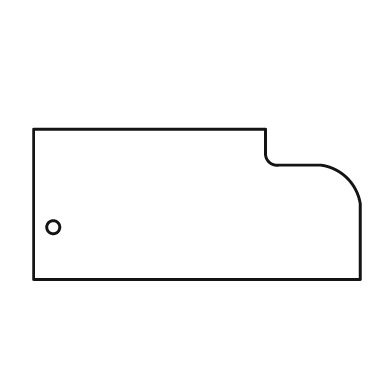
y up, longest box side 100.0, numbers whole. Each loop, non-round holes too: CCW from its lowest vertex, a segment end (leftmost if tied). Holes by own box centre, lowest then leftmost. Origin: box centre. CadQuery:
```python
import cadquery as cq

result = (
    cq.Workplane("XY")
    .moveTo(-50.0, -23.0)
    .lineTo(50.0, -23.0)
    .lineTo(50.0, 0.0)
    .threePointArc((46.0, 8.0), (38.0, 12.0))
    .lineTo(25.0, 12.0)
    .threePointArc((22.0, 13.0), (21.0, 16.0))
    .lineTo(21.0, 23.0)
    .lineTo(-50.0, 23.0)
    .close()
    .moveTo(-44.0, -7.0)
    .circle(2.0)
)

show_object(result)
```